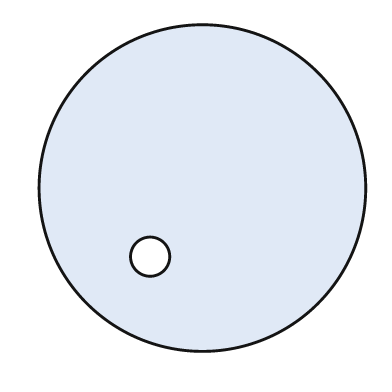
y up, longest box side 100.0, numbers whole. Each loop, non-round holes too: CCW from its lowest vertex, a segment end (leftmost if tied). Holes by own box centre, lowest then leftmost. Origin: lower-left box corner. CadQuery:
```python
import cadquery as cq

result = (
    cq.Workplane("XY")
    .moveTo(50.0, 50.0)
    .circle(50.0)
    .moveTo(34.0, 29.0)
    .circle(6.0)
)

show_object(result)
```